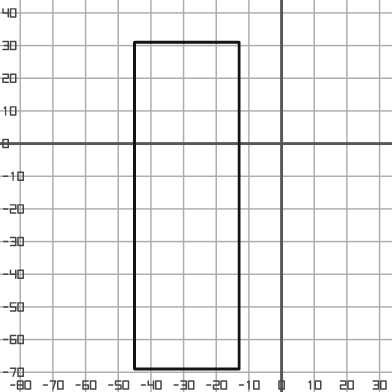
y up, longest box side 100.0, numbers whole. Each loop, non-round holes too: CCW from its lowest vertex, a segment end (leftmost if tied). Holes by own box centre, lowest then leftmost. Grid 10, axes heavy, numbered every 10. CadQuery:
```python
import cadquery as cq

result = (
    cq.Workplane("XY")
    .moveTo(-45.0, -69.0)
    .lineTo(-13.0, -69.0)
    .lineTo(-13.0, 31.0)
    .lineTo(-45.0, 31.0)
    .close()
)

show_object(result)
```